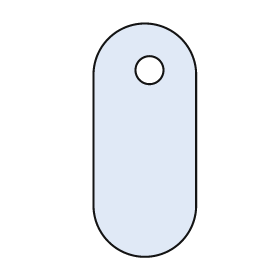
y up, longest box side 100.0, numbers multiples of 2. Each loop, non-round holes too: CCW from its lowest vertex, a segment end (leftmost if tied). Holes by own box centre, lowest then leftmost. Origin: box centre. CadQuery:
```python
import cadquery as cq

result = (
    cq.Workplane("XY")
    .moveTo(-22.0, -28.0)
    .threePointArc((0.0, -50.0), (22.0, -28.0))
    .lineTo(22.0, 28.0)
    .threePointArc((0.0, 50.0), (-22.0, 28.0))
    .close()
    .moveTo(2.0, 30.0)
    .circle(6.0)
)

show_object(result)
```